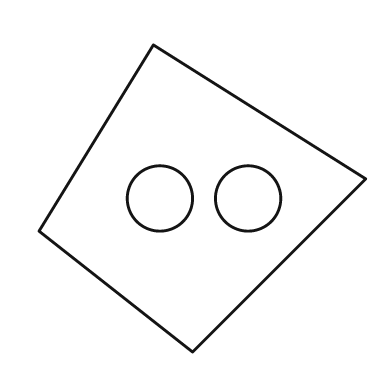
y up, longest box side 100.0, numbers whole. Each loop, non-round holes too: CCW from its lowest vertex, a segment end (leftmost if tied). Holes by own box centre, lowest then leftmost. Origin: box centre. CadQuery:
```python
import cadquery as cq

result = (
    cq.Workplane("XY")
    .moveTo(-3.0, -47.0)
    .lineTo(50.0, 6.0)
    .lineTo(-15.0, 47.0)
    .lineTo(-50.0, -10.0)
    .close()
    .moveTo(-13.0, 0.0)
    .circle(10.0)
    .moveTo(14.0, 0.0)
    .circle(10.0)
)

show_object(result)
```